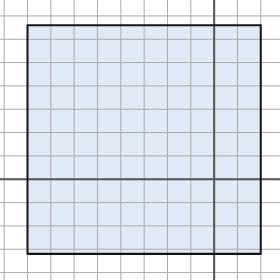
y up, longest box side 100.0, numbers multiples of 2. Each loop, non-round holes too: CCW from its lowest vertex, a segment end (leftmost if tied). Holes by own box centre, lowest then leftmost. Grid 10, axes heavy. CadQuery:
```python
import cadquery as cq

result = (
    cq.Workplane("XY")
    .moveTo(-80.0, -32.0)
    .lineTo(20.0, -32.0)
    .lineTo(20.0, 66.0)
    .lineTo(-80.0, 66.0)
    .close()
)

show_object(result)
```